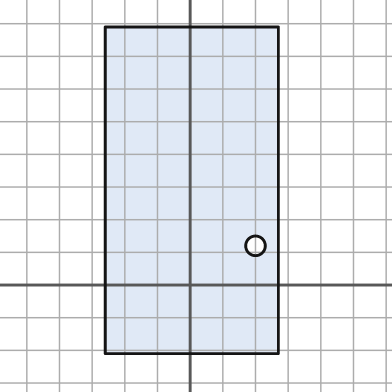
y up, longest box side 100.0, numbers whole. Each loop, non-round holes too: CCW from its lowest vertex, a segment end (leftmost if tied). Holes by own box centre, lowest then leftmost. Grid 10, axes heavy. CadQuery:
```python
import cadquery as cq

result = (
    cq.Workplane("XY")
    .moveTo(-26.0, -21.0)
    .lineTo(27.0, -21.0)
    .lineTo(27.0, 79.0)
    .lineTo(-26.0, 79.0)
    .close()
    .moveTo(20.0, 12.0)
    .circle(3.0)
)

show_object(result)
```